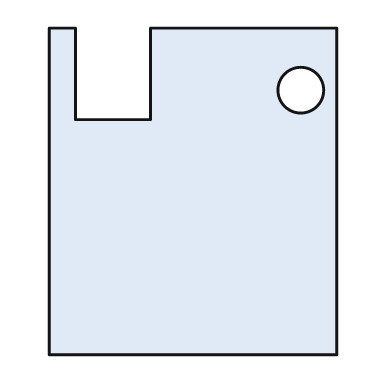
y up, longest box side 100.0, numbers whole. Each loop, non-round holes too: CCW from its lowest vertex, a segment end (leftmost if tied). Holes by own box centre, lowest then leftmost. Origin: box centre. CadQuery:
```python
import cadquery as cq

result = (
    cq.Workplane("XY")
    .moveTo(-44.0, -50.0)
    .lineTo(44.0, -50.0)
    .lineTo(44.0, 50.0)
    .lineTo(-13.0, 50.0)
    .lineTo(-13.0, 22.0)
    .lineTo(-36.0, 22.0)
    .lineTo(-36.0, 50.0)
    .lineTo(-44.0, 50.0)
    .close()
    .moveTo(33.0, 31.0)
    .circle(7.0)
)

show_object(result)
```